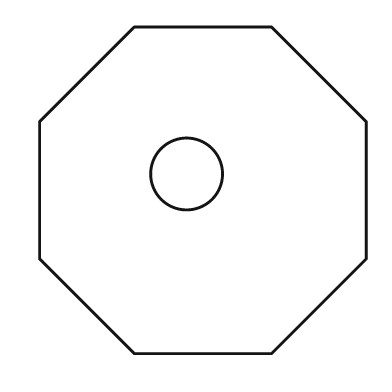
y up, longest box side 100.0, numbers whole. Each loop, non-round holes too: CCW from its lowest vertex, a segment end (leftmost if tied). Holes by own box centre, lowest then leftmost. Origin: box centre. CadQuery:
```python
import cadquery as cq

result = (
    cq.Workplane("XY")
    .moveTo(-21.0, -50.0)
    .lineTo(21.0, -50.0)
    .lineTo(50.0, -21.0)
    .lineTo(50.0, 21.0)
    .lineTo(21.0, 50.0)
    .lineTo(-21.0, 50.0)
    .lineTo(-50.0, 21.0)
    .lineTo(-50.0, -21.0)
    .close()
    .moveTo(-5.0, 5.0)
    .circle(11.0)
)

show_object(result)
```